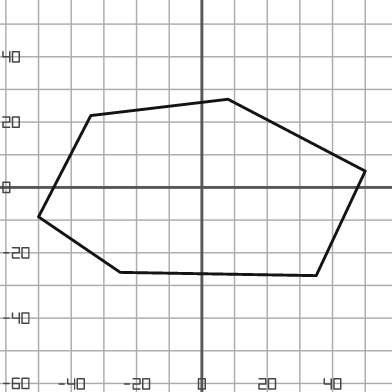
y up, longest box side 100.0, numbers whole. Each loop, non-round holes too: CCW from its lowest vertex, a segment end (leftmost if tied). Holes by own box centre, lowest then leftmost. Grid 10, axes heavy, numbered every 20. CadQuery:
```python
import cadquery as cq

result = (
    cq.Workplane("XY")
    .moveTo(35.0, -27.0)
    .lineTo(50.0, 5.0)
    .lineTo(8.0, 27.0)
    .lineTo(-34.0, 22.0)
    .lineTo(-50.0, -9.0)
    .lineTo(-25.0, -26.0)
    .close()
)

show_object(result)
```